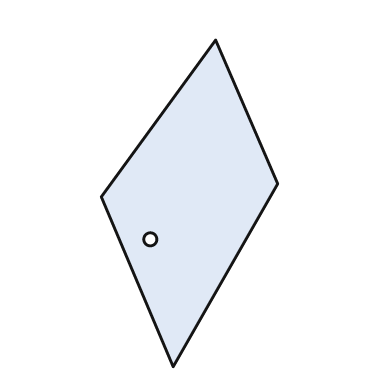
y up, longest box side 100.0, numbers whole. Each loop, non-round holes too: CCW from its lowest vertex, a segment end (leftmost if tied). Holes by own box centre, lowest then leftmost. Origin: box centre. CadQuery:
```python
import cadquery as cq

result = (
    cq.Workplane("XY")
    .moveTo(-5.0, -50.0)
    .lineTo(27.0, 6.0)
    .lineTo(8.0, 50.0)
    .lineTo(-27.0, 2.0)
    .close()
    .moveTo(-12.0, -11.0)
    .circle(2.0)
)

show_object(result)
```